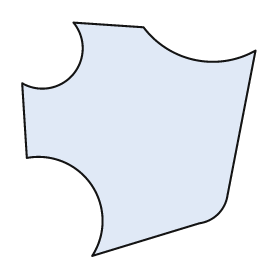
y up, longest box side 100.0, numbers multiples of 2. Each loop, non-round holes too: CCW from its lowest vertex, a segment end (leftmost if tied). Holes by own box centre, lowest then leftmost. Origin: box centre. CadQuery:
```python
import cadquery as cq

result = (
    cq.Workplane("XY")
    .moveTo(-20.0, -50.0)
    .lineTo(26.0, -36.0)
    .threePointArc((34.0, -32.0), (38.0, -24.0))
    .lineTo(50.0, 38.0)
    .threePointArc((24.0, 34.0), (2.0, 48.0))
    .lineTo(-28.0, 50.0)
    .threePointArc((-28.0, 28.0), (-50.0, 24.0))
    .lineTo(-48.0, -8.0)
    .threePointArc((-20.0, -20.0), (-20.0, -50.0))
    .close()
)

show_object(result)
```